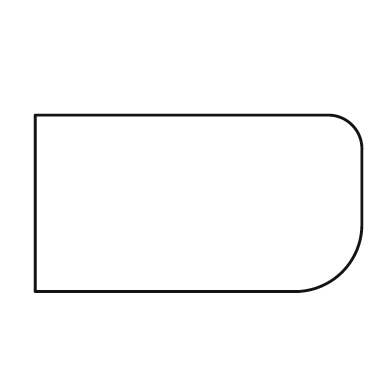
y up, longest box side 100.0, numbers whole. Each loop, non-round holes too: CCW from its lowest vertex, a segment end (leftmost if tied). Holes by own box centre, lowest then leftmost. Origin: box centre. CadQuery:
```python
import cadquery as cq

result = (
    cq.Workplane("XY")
    .moveTo(-50.0, -27.0)
    .lineTo(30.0, -27.0)
    .threePointArc((44.0, -21.0), (50.0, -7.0))
    .lineTo(50.0, 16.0)
    .threePointArc((47.0, 24.0), (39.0, 27.0))
    .lineTo(-50.0, 27.0)
    .close()
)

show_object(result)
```